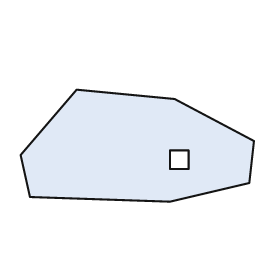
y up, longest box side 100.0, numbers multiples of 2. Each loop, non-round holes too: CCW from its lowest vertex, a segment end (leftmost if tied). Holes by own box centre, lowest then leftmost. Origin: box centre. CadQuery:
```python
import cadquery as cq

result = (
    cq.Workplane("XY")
    .moveTo(14.0, -24.0)
    .lineTo(48.0, -16.0)
    .lineTo(50.0, 2.0)
    .lineTo(16.0, 20.0)
    .lineTo(-26.0, 24.0)
    .lineTo(-50.0, -4.0)
    .lineTo(-46.0, -22.0)
    .close()
    .moveTo(14.0, -10.0)
    .lineTo(22.0, -10.0)
    .lineTo(22.0, -2.0)
    .lineTo(14.0, -2.0)
    .close()
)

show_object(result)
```